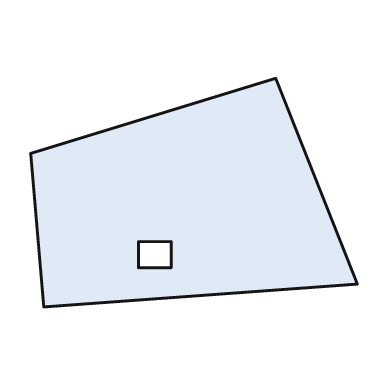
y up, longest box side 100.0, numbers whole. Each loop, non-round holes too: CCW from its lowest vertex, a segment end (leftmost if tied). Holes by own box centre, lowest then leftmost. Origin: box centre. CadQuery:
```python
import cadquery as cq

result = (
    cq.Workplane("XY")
    .moveTo(-46.0, -35.0)
    .lineTo(50.0, -28.0)
    .lineTo(25.0, 35.0)
    .lineTo(-50.0, 12.0)
    .close()
    .moveTo(-17.0, -23.0)
    .lineTo(-7.0, -23.0)
    .lineTo(-7.0, -15.0)
    .lineTo(-17.0, -15.0)
    .close()
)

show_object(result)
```